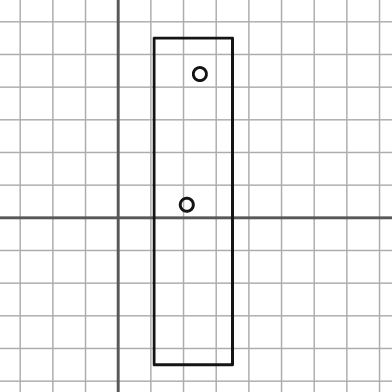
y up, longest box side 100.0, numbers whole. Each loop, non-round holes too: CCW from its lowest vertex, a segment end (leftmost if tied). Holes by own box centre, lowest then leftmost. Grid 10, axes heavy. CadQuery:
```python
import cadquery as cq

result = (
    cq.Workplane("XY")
    .moveTo(11.0, -45.0)
    .lineTo(35.0, -45.0)
    .lineTo(35.0, 55.0)
    .lineTo(11.0, 55.0)
    .close()
    .moveTo(21.0, 4.0)
    .circle(2.0)
    .moveTo(25.0, 44.0)
    .circle(2.0)
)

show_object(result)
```